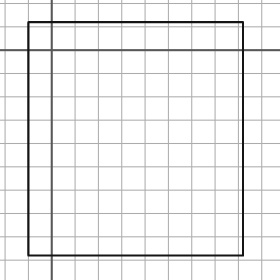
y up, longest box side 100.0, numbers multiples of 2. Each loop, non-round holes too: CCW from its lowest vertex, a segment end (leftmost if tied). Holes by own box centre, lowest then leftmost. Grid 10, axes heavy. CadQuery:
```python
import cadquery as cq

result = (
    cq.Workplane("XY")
    .moveTo(-10.0, -88.0)
    .lineTo(82.0, -88.0)
    .lineTo(82.0, 12.0)
    .lineTo(-10.0, 12.0)
    .close()
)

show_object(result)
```